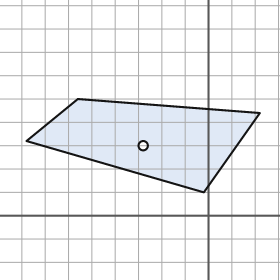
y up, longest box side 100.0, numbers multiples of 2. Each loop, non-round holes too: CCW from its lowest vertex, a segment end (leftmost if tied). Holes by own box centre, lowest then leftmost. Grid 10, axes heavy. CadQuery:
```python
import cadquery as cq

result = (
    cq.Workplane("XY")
    .moveTo(-2.0, 10.0)
    .lineTo(22.0, 44.0)
    .lineTo(-56.0, 50.0)
    .lineTo(-78.0, 32.0)
    .close()
    .moveTo(-28.0, 30.0)
    .circle(2.0)
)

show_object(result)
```